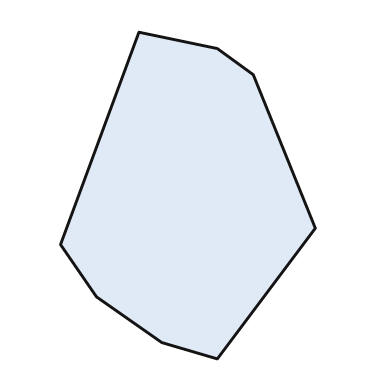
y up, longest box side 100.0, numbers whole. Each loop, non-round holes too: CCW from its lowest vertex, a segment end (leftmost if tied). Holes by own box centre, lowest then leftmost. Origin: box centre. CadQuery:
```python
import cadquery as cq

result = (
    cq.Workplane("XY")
    .moveTo(9.0, -50.0)
    .lineTo(39.0, -10.0)
    .lineTo(20.0, 37.0)
    .lineTo(9.0, 45.0)
    .lineTo(-15.0, 50.0)
    .lineTo(-39.0, -15.0)
    .lineTo(-28.0, -31.0)
    .lineTo(-8.0, -45.0)
    .close()
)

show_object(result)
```